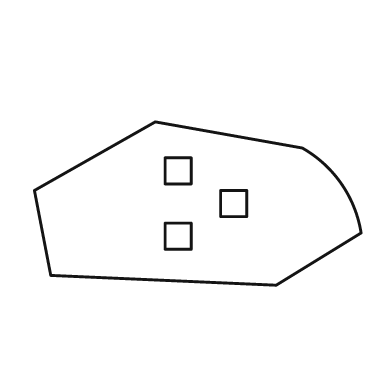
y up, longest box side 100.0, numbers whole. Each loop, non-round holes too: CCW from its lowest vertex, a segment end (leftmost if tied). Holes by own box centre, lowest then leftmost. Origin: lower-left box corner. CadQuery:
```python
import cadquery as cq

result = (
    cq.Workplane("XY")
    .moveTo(74.0, 0.0)
    .lineTo(100.0, 16.0)
    .threePointArc((94.0, 31.0), (82.0, 42.0))
    .lineTo(37.0, 50.0)
    .lineTo(0.0, 29.0)
    .lineTo(5.0, 3.0)
    .close()
    .moveTo(40.0, 11.0)
    .lineTo(48.0, 11.0)
    .lineTo(48.0, 19.0)
    .lineTo(40.0, 19.0)
    .close()
    .moveTo(57.0, 21.0)
    .lineTo(65.0, 21.0)
    .lineTo(65.0, 29.0)
    .lineTo(57.0, 29.0)
    .close()
    .moveTo(40.0, 31.0)
    .lineTo(48.0, 31.0)
    .lineTo(48.0, 39.0)
    .lineTo(40.0, 39.0)
    .close()
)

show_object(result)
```